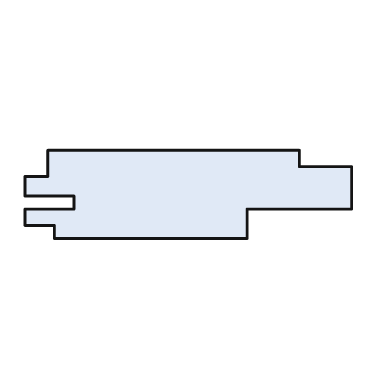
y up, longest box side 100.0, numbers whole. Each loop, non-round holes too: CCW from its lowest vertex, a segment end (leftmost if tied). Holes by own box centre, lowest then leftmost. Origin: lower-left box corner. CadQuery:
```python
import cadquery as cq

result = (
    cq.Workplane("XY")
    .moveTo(9.0, 0.0)
    .lineTo(68.0, 0.0)
    .lineTo(68.0, 9.0)
    .lineTo(100.0, 9.0)
    .lineTo(100.0, 22.0)
    .lineTo(84.0, 22.0)
    .lineTo(84.0, 27.0)
    .lineTo(7.0, 27.0)
    .lineTo(7.0, 19.0)
    .lineTo(0.0, 19.0)
    .lineTo(0.0, 13.0)
    .lineTo(15.0, 13.0)
    .lineTo(15.0, 9.0)
    .lineTo(0.0, 9.0)
    .lineTo(0.0, 4.0)
    .lineTo(9.0, 4.0)
    .close()
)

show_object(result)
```